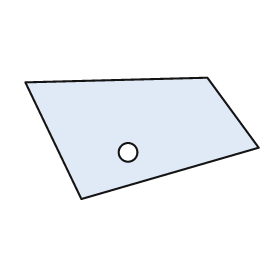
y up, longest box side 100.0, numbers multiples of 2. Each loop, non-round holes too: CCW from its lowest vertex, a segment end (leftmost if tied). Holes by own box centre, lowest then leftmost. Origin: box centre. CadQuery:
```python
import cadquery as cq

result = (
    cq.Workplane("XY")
    .moveTo(-26.0, -26.0)
    .lineTo(50.0, -4.0)
    .lineTo(28.0, 26.0)
    .lineTo(-50.0, 24.0)
    .close()
    .moveTo(-6.0, -6.0)
    .circle(4.0)
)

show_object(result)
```